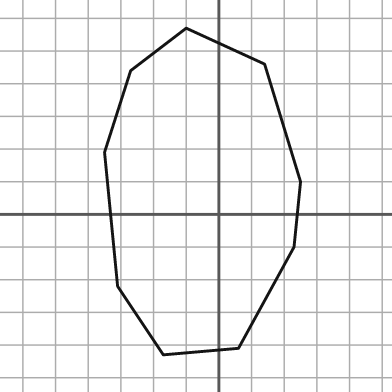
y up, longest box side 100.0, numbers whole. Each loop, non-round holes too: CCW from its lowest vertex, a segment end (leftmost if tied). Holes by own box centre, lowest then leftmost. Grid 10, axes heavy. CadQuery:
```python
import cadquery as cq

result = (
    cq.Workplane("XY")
    .moveTo(-17.0, -43.0)
    .lineTo(6.0, -41.0)
    .lineTo(23.0, -10.0)
    .lineTo(25.0, 10.0)
    .lineTo(14.0, 46.0)
    .lineTo(-10.0, 57.0)
    .lineTo(-27.0, 44.0)
    .lineTo(-35.0, 19.0)
    .lineTo(-31.0, -22.0)
    .close()
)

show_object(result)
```